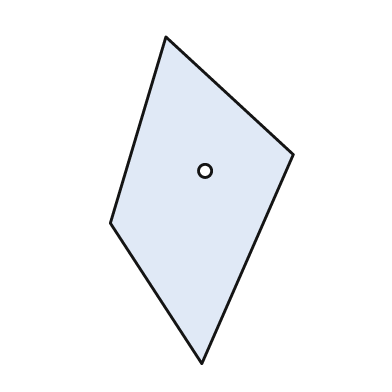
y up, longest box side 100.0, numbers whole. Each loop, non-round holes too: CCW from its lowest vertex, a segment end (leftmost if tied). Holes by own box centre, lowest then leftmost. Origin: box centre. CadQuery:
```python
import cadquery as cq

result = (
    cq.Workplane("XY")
    .moveTo(0.0, -50.0)
    .lineTo(28.0, 14.0)
    .lineTo(-11.0, 50.0)
    .lineTo(-28.0, -7.0)
    .close()
    .moveTo(1.0, 9.0)
    .circle(2.0)
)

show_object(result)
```